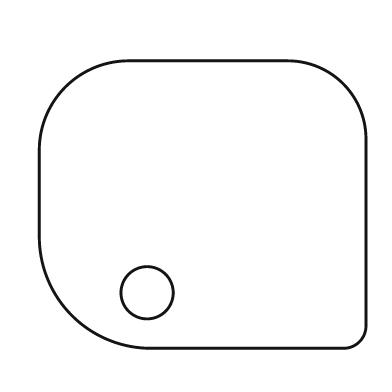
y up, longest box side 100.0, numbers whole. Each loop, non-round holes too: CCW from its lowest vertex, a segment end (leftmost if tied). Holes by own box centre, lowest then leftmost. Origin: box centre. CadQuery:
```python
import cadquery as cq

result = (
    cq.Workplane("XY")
    .moveTo(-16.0, -44.0)
    .lineTo(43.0, -44.0)
    .threePointArc((48.0, -42.0), (50.0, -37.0))
    .lineTo(50.0, 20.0)
    .threePointArc((43.0, 37.0), (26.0, 44.0))
    .lineTo(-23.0, 44.0)
    .threePointArc((-42.0, 36.0), (-50.0, 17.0))
    .lineTo(-50.0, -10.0)
    .threePointArc((-40.0, -34.0), (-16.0, -44.0))
    .close()
    .moveTo(-17.0, -27.0)
    .circle(8.0)
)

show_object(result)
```